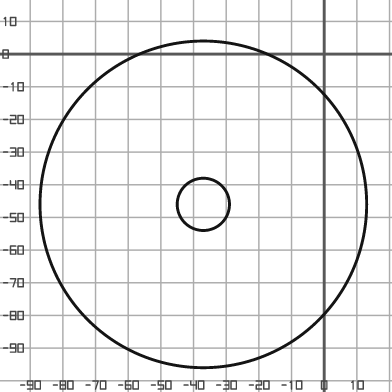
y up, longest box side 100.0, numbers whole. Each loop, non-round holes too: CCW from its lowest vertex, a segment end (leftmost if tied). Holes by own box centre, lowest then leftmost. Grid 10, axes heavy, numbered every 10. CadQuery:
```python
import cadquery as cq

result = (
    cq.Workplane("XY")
    .moveTo(-37.0, -46.0)
    .circle(50.0)
    .moveTo(-37.0, -46.0)
    .circle(8.0)
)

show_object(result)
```